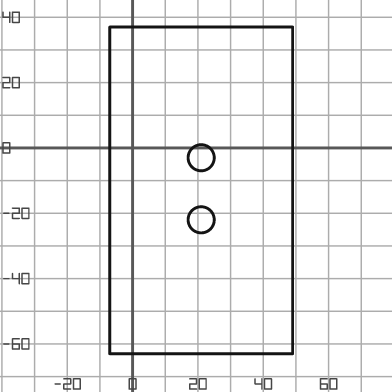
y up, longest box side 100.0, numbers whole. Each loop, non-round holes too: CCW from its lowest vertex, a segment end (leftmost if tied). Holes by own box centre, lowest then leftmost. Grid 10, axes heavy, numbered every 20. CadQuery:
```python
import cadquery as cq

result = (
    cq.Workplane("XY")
    .moveTo(-7.0, -63.0)
    .lineTo(49.0, -63.0)
    .lineTo(49.0, 37.0)
    .lineTo(-7.0, 37.0)
    .close()
    .moveTo(21.0, -22.0)
    .circle(4.0)
    .moveTo(21.0, -3.0)
    .circle(4.0)
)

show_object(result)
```